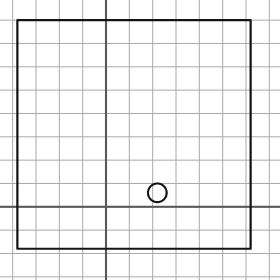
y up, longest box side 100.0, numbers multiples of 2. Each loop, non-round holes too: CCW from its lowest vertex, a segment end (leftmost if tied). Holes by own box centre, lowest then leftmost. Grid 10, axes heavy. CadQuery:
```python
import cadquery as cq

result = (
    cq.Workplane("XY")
    .moveTo(-38.0, -18.0)
    .lineTo(62.0, -18.0)
    .lineTo(62.0, 80.0)
    .lineTo(-38.0, 80.0)
    .close()
    .moveTo(22.0, 6.0)
    .circle(4.0)
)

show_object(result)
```